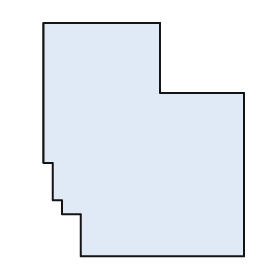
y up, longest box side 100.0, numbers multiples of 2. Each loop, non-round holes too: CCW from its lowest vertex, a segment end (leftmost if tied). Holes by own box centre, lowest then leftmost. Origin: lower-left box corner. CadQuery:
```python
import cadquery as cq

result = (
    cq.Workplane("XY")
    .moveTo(16.0, 0.0)
    .lineTo(86.0, 0.0)
    .lineTo(86.0, 70.0)
    .lineTo(50.0, 70.0)
    .lineTo(50.0, 100.0)
    .lineTo(0.0, 100.0)
    .lineTo(0.0, 40.0)
    .lineTo(4.0, 40.0)
    .lineTo(4.0, 24.0)
    .lineTo(8.0, 24.0)
    .lineTo(8.0, 18.0)
    .lineTo(16.0, 18.0)
    .close()
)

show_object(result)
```